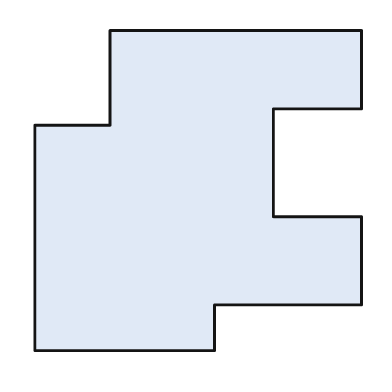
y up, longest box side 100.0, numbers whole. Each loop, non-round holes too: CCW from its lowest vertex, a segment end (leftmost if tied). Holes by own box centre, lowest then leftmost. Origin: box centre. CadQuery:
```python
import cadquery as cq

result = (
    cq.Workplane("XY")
    .moveTo(-50.0, -49.0)
    .lineTo(5.0, -49.0)
    .lineTo(5.0, -35.0)
    .lineTo(50.0, -35.0)
    .lineTo(50.0, -8.0)
    .lineTo(23.0, -8.0)
    .lineTo(23.0, 25.0)
    .lineTo(50.0, 25.0)
    .lineTo(50.0, 49.0)
    .lineTo(-27.0, 49.0)
    .lineTo(-27.0, 20.0)
    .lineTo(-50.0, 20.0)
    .close()
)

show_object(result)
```